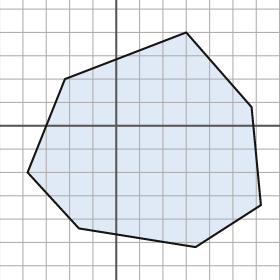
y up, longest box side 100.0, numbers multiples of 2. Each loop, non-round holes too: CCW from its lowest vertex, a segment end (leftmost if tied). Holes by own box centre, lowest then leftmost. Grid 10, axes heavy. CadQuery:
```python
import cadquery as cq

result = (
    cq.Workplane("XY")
    .moveTo(34.0, -52.0)
    .lineTo(62.0, -34.0)
    .lineTo(58.0, 8.0)
    .lineTo(30.0, 40.0)
    .lineTo(-22.0, 20.0)
    .lineTo(-38.0, -20.0)
    .lineTo(-16.0, -44.0)
    .close()
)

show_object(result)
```